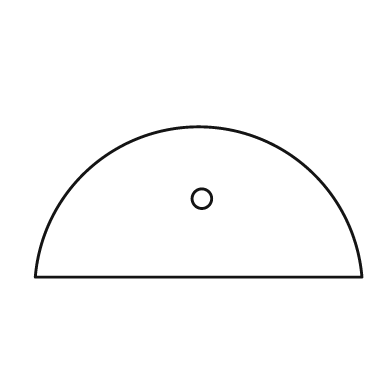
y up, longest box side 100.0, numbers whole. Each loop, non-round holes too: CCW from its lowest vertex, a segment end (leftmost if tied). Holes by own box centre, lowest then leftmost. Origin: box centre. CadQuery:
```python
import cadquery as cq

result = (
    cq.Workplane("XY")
    .moveTo(-50.0, -23.0)
    .lineTo(50.0, -23.0)
    .threePointArc((0.0, 23.0), (-50.0, -23.0))
    .close()
    .moveTo(1.0, 1.0)
    .circle(3.0)
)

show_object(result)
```